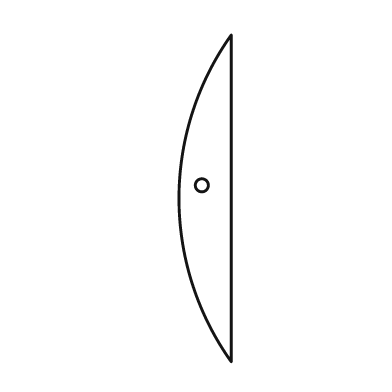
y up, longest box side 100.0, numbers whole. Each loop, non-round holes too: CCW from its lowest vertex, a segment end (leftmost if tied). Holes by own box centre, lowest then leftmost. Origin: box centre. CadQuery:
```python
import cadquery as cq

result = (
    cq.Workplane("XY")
    .moveTo(8.0, -50.0)
    .lineTo(8.0, 50.0)
    .threePointArc((-8.0, 0.0), (8.0, -50.0))
    .close()
    .moveTo(-1.0, 4.0)
    .circle(2.0)
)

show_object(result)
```